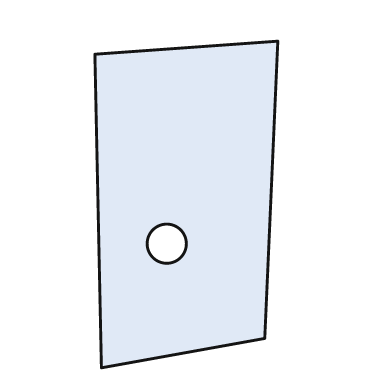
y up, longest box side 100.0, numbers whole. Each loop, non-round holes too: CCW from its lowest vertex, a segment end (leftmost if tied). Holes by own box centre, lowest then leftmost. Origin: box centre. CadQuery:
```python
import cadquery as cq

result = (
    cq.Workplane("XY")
    .moveTo(-26.0, -50.0)
    .lineTo(24.0, -41.0)
    .lineTo(28.0, 50.0)
    .lineTo(-28.0, 46.0)
    .close()
    .moveTo(-6.0, -12.0)
    .circle(6.0)
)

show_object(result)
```